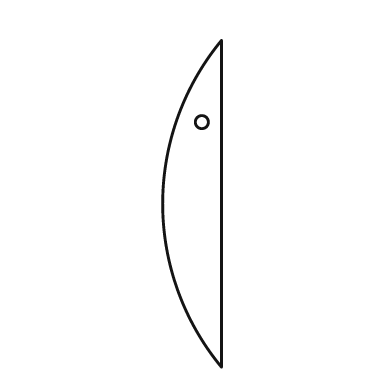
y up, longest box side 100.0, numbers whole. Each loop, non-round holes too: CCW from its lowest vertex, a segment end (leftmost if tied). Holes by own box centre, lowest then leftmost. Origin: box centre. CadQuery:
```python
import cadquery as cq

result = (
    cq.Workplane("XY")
    .moveTo(9.0, -50.0)
    .lineTo(9.0, 50.0)
    .threePointArc((-9.0, 0.0), (9.0, -50.0))
    .close()
    .moveTo(3.0, 25.0)
    .circle(2.0)
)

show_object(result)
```